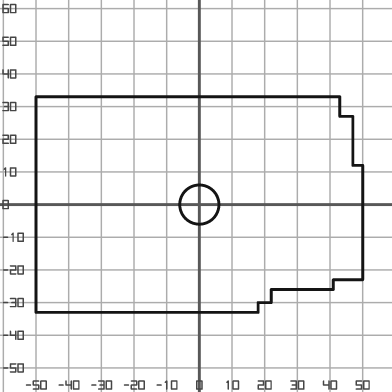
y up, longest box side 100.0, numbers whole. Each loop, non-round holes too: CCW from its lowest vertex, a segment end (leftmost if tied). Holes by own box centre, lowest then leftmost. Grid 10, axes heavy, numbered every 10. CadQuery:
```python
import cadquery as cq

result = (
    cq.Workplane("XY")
    .moveTo(-50.0, -33.0)
    .lineTo(18.0, -33.0)
    .lineTo(18.0, -30.0)
    .lineTo(22.0, -30.0)
    .lineTo(22.0, -26.0)
    .lineTo(41.0, -26.0)
    .lineTo(41.0, -23.0)
    .lineTo(50.0, -23.0)
    .lineTo(50.0, 12.0)
    .lineTo(47.0, 12.0)
    .lineTo(47.0, 27.0)
    .lineTo(43.0, 27.0)
    .lineTo(43.0, 33.0)
    .lineTo(-50.0, 33.0)
    .close()
    .moveTo(0.0, 0.0)
    .circle(6.0)
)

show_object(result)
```